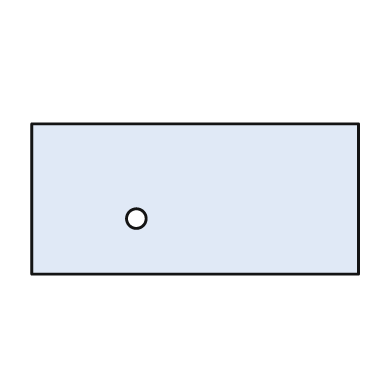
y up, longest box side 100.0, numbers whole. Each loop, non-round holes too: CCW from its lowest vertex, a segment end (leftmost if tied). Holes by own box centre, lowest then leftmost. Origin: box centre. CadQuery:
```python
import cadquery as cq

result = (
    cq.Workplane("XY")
    .moveTo(-50.0, -23.0)
    .lineTo(50.0, -23.0)
    .lineTo(50.0, 23.0)
    .lineTo(-50.0, 23.0)
    .close()
    .moveTo(-18.0, -6.0)
    .circle(3.0)
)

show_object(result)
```